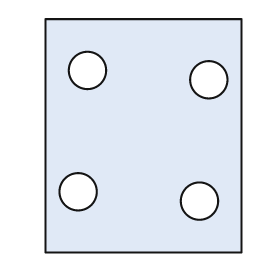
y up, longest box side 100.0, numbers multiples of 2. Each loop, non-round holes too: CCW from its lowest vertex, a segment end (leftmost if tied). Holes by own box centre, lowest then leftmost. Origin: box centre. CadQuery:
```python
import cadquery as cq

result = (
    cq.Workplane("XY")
    .moveTo(-42.0, -50.0)
    .lineTo(42.0, -50.0)
    .lineTo(42.0, 50.0)
    .lineTo(-42.0, 50.0)
    .close()
    .moveTo(24.0, -28.0)
    .circle(8.0)
    .moveTo(-28.0, -24.0)
    .circle(8.0)
    .moveTo(28.0, 24.0)
    .circle(8.0)
    .moveTo(-24.0, 28.0)
    .circle(8.0)
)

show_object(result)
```